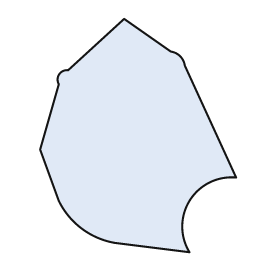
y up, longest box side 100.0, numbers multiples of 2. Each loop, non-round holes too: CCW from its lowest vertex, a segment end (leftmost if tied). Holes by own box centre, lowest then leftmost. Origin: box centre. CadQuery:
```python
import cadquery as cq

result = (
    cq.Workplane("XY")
    .moveTo(22.0, -50.0)
    .threePointArc((22.0, -28.0), (42.0, -18.0))
    .lineTo(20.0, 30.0)
    .threePointArc((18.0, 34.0), (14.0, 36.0))
    .lineTo(-6.0, 50.0)
    .lineTo(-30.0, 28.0)
    .threePointArc((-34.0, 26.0), (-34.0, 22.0))
    .lineTo(-42.0, -6.0)
    .lineTo(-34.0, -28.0)
    .threePointArc((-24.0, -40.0), (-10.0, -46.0))
    .close()
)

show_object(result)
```